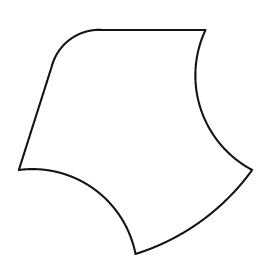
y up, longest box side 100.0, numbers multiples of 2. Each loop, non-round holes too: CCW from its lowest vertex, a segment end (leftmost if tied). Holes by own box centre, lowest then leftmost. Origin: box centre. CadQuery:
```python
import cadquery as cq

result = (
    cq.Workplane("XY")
    .moveTo(0.0, -48.0)
    .threePointArc((28.0, -34.0), (50.0, -12.0))
    .threePointArc((28.0, 14.0), (30.0, 48.0))
    .lineTo(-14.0, 48.0)
    .threePointArc((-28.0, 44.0), (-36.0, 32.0))
    .lineTo(-50.0, -12.0)
    .threePointArc((-18.0, -20.0), (0.0, -48.0))
    .close()
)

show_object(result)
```